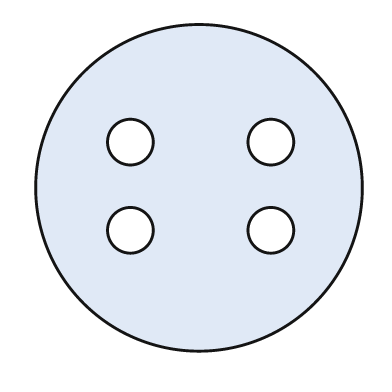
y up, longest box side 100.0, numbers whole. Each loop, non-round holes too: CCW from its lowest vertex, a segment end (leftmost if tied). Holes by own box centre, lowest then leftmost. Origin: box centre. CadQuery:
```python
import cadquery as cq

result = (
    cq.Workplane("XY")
    .moveTo(0.0, 0.0)
    .circle(50.0)
    .moveTo(-21.0, -13.0)
    .circle(7.0)
    .moveTo(22.0, -13.0)
    .circle(7.0)
    .moveTo(-21.0, 14.0)
    .circle(7.0)
    .moveTo(22.0, 14.0)
    .circle(7.0)
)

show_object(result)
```